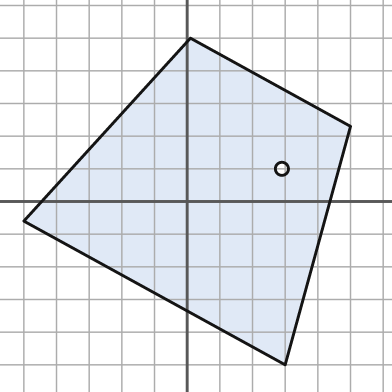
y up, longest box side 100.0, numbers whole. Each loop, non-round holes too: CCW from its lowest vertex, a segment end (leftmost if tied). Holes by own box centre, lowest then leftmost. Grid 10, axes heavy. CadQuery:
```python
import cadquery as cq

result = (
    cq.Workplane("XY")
    .moveTo(30.0, -50.0)
    .lineTo(50.0, 23.0)
    .lineTo(1.0, 50.0)
    .lineTo(-50.0, -6.0)
    .close()
    .moveTo(29.0, 10.0)
    .circle(2.0)
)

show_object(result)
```